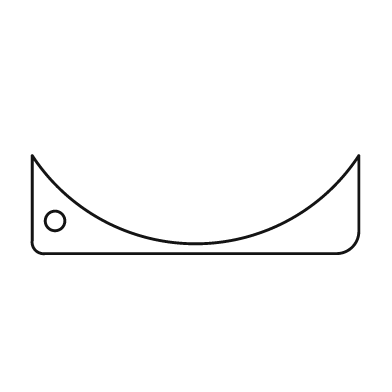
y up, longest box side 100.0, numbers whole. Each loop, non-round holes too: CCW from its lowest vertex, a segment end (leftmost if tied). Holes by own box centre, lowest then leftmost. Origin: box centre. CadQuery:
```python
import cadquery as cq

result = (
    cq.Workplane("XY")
    .moveTo(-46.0, -15.0)
    .lineTo(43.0, -15.0)
    .threePointArc((48.0, -13.0), (50.0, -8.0))
    .lineTo(50.0, 15.0)
    .threePointArc((0.0, -12.0), (-50.0, 15.0))
    .lineTo(-50.0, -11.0)
    .threePointArc((-49.0, -14.0), (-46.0, -15.0))
    .close()
    .moveTo(-43.0, -5.0)
    .circle(3.0)
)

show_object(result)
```